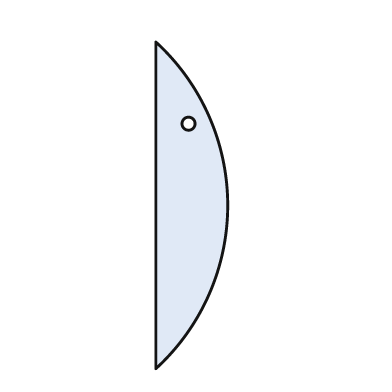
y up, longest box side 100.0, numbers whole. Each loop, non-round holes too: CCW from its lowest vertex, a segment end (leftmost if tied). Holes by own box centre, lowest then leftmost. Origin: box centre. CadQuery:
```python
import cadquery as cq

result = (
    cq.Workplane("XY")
    .moveTo(-11.0, -50.0)
    .threePointArc((11.0, 0.0), (-11.0, 50.0))
    .close()
    .moveTo(-1.0, 25.0)
    .circle(2.0)
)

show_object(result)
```